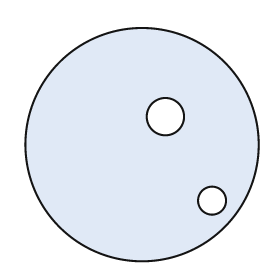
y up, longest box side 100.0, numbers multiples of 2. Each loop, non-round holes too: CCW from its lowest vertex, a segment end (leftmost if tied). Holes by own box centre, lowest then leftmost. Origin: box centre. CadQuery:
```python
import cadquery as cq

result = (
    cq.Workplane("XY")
    .moveTo(0.0, 0.0)
    .circle(50.0)
    .moveTo(30.0, -24.0)
    .circle(6.0)
    .moveTo(10.0, 12.0)
    .circle(8.0)
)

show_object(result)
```